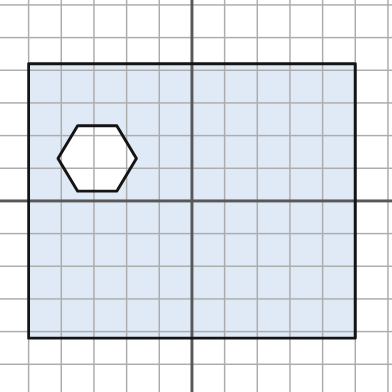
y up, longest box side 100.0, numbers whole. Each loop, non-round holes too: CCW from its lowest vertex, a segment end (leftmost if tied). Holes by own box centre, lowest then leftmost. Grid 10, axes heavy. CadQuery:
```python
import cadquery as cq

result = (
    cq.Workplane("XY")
    .moveTo(-50.0, -42.0)
    .lineTo(50.0, -42.0)
    .lineTo(50.0, 42.0)
    .lineTo(-50.0, 42.0)
    .close()
    .moveTo(-35.0, 3.0)
    .lineTo(-23.0, 3.0)
    .lineTo(-17.0, 13.0)
    .lineTo(-23.0, 23.0)
    .lineTo(-35.0, 23.0)
    .lineTo(-41.0, 13.0)
    .close()
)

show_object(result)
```